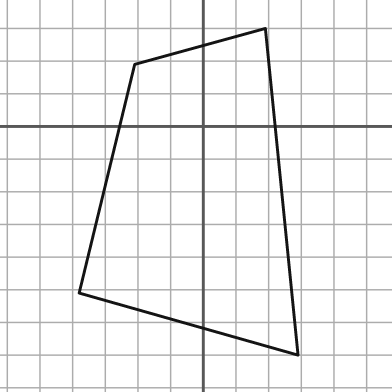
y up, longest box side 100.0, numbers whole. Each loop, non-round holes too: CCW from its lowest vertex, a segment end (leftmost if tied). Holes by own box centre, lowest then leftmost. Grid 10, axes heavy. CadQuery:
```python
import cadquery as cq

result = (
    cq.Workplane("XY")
    .moveTo(29.0, -70.0)
    .lineTo(19.0, 30.0)
    .lineTo(-21.0, 19.0)
    .lineTo(-38.0, -51.0)
    .close()
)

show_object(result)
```